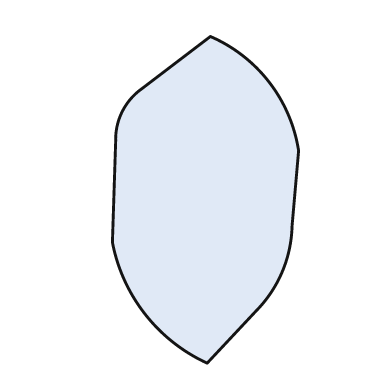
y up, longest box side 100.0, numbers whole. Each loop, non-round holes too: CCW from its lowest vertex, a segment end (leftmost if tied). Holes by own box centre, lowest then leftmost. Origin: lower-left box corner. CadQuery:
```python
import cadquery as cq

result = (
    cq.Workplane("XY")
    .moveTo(29.0, 0.0)
    .lineTo(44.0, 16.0)
    .threePointArc((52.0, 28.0), (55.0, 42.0))
    .lineTo(57.0, 65.0)
    .threePointArc((48.0, 86.0), (30.0, 100.0))
    .lineTo(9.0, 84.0)
    .threePointArc((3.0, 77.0), (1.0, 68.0))
    .lineTo(0.0, 37.0)
    .threePointArc((10.0, 15.0), (29.0, 0.0))
    .close()
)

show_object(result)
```